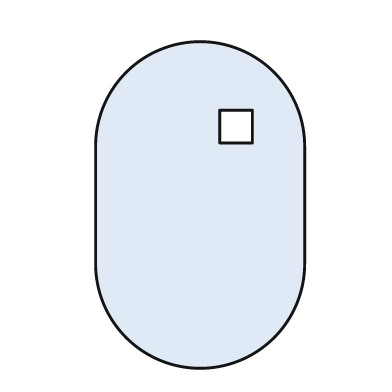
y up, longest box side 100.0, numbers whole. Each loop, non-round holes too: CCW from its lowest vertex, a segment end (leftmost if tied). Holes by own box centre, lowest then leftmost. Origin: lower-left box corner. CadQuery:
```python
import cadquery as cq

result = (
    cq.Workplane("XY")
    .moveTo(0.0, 32.0)
    .threePointArc((32.0, 0.0), (64.0, 32.0))
    .lineTo(64.0, 68.0)
    .threePointArc((32.0, 100.0), (0.0, 68.0))
    .close()
    .moveTo(38.0, 69.0)
    .lineTo(48.0, 69.0)
    .lineTo(48.0, 79.0)
    .lineTo(38.0, 79.0)
    .close()
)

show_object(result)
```